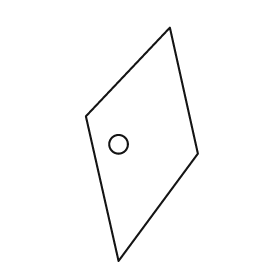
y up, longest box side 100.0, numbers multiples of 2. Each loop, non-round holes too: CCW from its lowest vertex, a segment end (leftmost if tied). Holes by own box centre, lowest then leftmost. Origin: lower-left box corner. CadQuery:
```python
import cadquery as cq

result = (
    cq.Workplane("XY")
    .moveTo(14.0, 0.0)
    .lineTo(48.0, 46.0)
    .lineTo(36.0, 100.0)
    .lineTo(0.0, 62.0)
    .close()
    .moveTo(14.0, 50.0)
    .circle(4.0)
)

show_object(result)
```